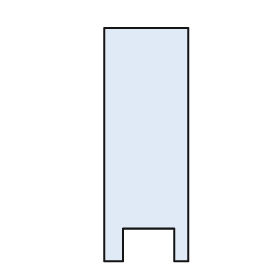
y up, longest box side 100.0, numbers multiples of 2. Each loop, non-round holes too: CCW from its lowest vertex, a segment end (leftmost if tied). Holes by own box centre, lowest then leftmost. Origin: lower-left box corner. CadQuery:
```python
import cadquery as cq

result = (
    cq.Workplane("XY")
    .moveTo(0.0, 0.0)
    .lineTo(8.0, 0.0)
    .lineTo(8.0, 14.0)
    .lineTo(30.0, 14.0)
    .lineTo(30.0, 0.0)
    .lineTo(36.0, 0.0)
    .lineTo(36.0, 100.0)
    .lineTo(0.0, 100.0)
    .close()
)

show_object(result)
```